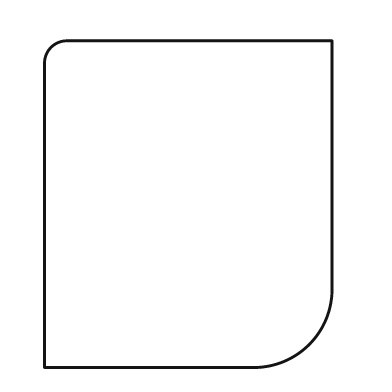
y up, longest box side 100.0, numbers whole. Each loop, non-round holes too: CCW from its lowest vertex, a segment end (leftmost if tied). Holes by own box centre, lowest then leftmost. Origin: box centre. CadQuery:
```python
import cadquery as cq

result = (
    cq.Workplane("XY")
    .moveTo(-44.0, -50.0)
    .lineTo(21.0, -50.0)
    .threePointArc((37.0, -43.0), (44.0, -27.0))
    .lineTo(44.0, 50.0)
    .lineTo(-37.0, 50.0)
    .threePointArc((-42.0, 48.0), (-44.0, 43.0))
    .close()
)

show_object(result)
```